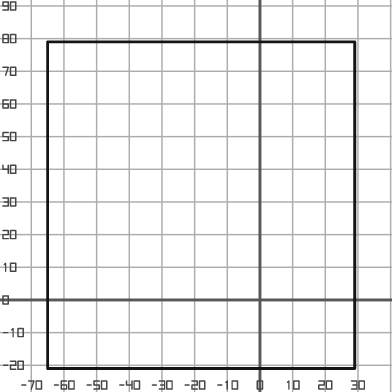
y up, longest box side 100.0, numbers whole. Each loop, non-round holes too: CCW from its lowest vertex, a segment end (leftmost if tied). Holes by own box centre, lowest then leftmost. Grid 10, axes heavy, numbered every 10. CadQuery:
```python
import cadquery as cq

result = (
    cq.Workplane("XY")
    .moveTo(-65.0, -21.0)
    .lineTo(29.0, -21.0)
    .lineTo(29.0, 79.0)
    .lineTo(-65.0, 79.0)
    .close()
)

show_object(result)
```